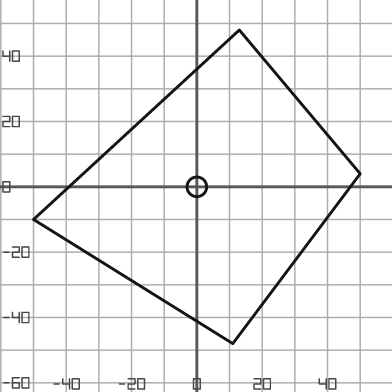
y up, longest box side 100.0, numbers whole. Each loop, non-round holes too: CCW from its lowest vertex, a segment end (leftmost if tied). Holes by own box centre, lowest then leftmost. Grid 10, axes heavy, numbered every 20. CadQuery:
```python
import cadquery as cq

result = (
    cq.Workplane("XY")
    .moveTo(11.0, -48.0)
    .lineTo(50.0, 4.0)
    .lineTo(13.0, 48.0)
    .lineTo(-50.0, -10.0)
    .close()
    .moveTo(0.0, 0.0)
    .circle(3.0)
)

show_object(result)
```